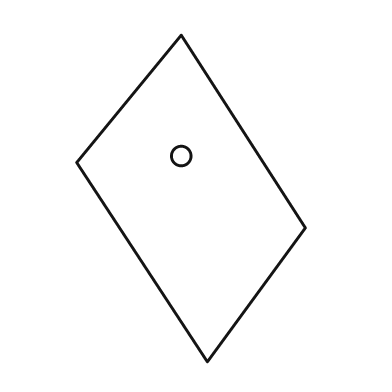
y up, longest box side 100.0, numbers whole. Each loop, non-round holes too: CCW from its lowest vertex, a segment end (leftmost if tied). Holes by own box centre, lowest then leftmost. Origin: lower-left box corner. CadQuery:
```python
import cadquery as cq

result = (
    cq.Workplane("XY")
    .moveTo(40.0, 0.0)
    .lineTo(70.0, 41.0)
    .lineTo(32.0, 100.0)
    .lineTo(0.0, 61.0)
    .close()
    .moveTo(32.0, 63.0)
    .circle(3.0)
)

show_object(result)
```